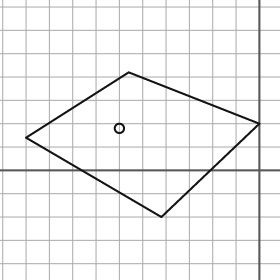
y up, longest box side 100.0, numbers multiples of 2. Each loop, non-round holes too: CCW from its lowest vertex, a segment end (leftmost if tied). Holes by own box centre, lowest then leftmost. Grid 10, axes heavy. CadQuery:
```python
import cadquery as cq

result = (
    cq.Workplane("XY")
    .moveTo(-42.0, -20.0)
    .lineTo(0.0, 20.0)
    .lineTo(-56.0, 42.0)
    .lineTo(-100.0, 14.0)
    .close()
    .moveTo(-60.0, 18.0)
    .circle(2.0)
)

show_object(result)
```